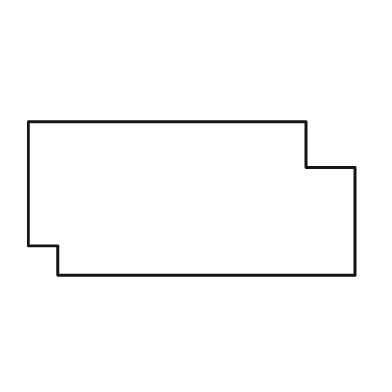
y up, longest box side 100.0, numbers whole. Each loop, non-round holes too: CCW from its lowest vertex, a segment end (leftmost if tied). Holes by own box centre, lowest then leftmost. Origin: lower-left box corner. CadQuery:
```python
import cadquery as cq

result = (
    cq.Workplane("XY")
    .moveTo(9.0, 0.0)
    .lineTo(100.0, 0.0)
    .lineTo(100.0, 33.0)
    .lineTo(85.0, 33.0)
    .lineTo(85.0, 47.0)
    .lineTo(0.0, 47.0)
    .lineTo(0.0, 9.0)
    .lineTo(9.0, 9.0)
    .close()
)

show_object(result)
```